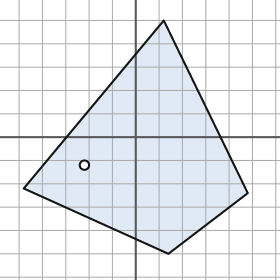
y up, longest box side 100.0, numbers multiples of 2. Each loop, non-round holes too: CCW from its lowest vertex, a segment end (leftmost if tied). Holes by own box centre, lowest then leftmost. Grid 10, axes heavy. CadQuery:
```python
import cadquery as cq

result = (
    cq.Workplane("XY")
    .moveTo(14.0, -50.0)
    .lineTo(48.0, -24.0)
    .lineTo(12.0, 50.0)
    .lineTo(-48.0, -22.0)
    .close()
    .moveTo(-22.0, -12.0)
    .circle(2.0)
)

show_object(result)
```